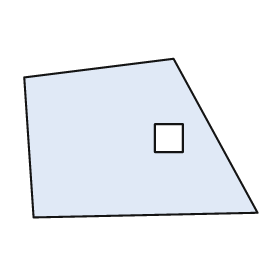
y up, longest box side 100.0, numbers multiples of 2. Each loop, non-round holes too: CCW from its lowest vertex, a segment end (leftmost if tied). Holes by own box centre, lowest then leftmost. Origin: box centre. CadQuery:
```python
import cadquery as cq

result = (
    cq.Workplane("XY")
    .moveTo(-46.0, -34.0)
    .lineTo(50.0, -32.0)
    .lineTo(14.0, 34.0)
    .lineTo(-50.0, 26.0)
    .close()
    .moveTo(6.0, -6.0)
    .lineTo(18.0, -6.0)
    .lineTo(18.0, 6.0)
    .lineTo(6.0, 6.0)
    .close()
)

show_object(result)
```